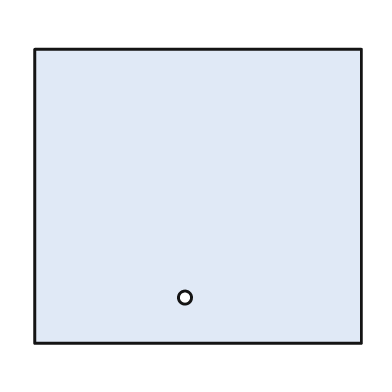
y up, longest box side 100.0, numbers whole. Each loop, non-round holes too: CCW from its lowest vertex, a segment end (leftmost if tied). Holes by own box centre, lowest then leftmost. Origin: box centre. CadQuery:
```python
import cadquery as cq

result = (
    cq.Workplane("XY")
    .moveTo(-50.0, -45.0)
    .lineTo(50.0, -45.0)
    .lineTo(50.0, 45.0)
    .lineTo(-50.0, 45.0)
    .close()
    .moveTo(-4.0, -31.0)
    .circle(2.0)
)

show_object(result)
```